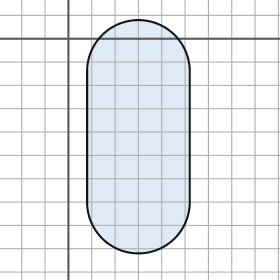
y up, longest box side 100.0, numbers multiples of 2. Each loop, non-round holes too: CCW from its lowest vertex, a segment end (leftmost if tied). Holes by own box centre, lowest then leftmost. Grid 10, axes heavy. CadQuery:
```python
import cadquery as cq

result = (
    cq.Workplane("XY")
    .moveTo(8.0, -70.0)
    .threePointArc((30.0, -92.0), (52.0, -70.0))
    .lineTo(52.0, -14.0)
    .threePointArc((30.0, 8.0), (8.0, -14.0))
    .close()
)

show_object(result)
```